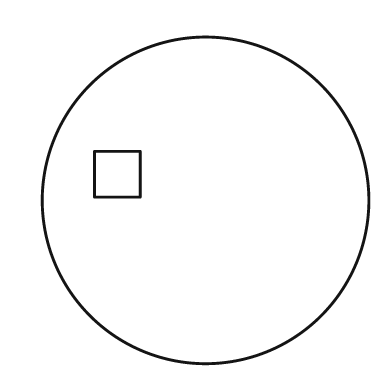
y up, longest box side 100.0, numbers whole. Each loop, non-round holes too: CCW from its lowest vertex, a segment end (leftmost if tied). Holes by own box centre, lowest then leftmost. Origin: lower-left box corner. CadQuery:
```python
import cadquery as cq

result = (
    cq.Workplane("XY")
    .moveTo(50.0, 50.0)
    .circle(50.0)
    .moveTo(16.0, 51.0)
    .lineTo(30.0, 51.0)
    .lineTo(30.0, 65.0)
    .lineTo(16.0, 65.0)
    .close()
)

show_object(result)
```